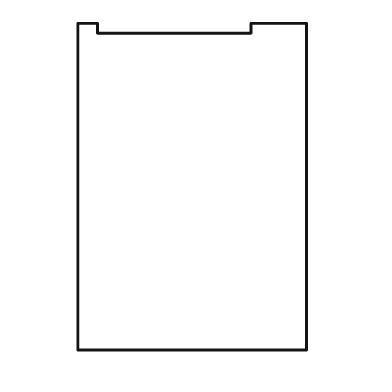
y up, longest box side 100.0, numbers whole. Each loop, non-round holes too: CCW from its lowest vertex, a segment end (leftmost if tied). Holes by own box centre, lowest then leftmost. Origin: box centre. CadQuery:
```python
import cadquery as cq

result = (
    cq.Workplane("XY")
    .moveTo(-35.0, -50.0)
    .lineTo(35.0, -50.0)
    .lineTo(35.0, 50.0)
    .lineTo(18.0, 50.0)
    .lineTo(18.0, 47.0)
    .lineTo(-29.0, 47.0)
    .lineTo(-29.0, 50.0)
    .lineTo(-35.0, 50.0)
    .close()
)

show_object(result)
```